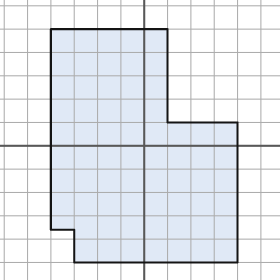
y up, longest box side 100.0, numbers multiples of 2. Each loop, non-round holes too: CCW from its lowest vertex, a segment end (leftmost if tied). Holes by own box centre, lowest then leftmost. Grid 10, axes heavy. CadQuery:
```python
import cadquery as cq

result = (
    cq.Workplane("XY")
    .moveTo(-30.0, -50.0)
    .lineTo(40.0, -50.0)
    .lineTo(40.0, 10.0)
    .lineTo(10.0, 10.0)
    .lineTo(10.0, 50.0)
    .lineTo(-40.0, 50.0)
    .lineTo(-40.0, -36.0)
    .lineTo(-30.0, -36.0)
    .close()
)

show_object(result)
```